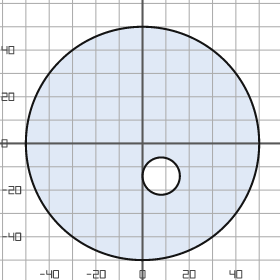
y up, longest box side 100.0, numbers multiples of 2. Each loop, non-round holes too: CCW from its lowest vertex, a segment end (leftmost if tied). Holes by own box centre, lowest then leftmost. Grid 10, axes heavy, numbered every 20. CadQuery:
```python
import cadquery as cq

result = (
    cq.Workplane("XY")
    .moveTo(0.0, 0.0)
    .circle(50.0)
    .moveTo(8.0, -14.0)
    .circle(8.0)
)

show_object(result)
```